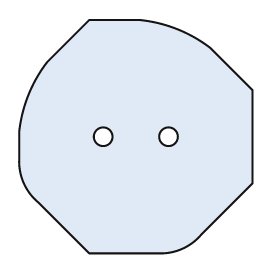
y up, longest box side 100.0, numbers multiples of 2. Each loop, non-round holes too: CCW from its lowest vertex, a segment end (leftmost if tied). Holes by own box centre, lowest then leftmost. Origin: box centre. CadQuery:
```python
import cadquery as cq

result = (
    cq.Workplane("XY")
    .moveTo(-20.0, -50.0)
    .lineTo(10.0, -50.0)
    .threePointArc((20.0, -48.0), (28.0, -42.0))
    .lineTo(50.0, -20.0)
    .lineTo(50.0, 20.0)
    .lineTo(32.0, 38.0)
    .threePointArc((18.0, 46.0), (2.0, 50.0))
    .lineTo(-20.0, 50.0)
    .lineTo(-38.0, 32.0)
    .threePointArc((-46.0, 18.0), (-50.0, 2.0))
    .lineTo(-50.0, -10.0)
    .threePointArc((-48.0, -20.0), (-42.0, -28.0))
    .close()
    .moveTo(-14.0, 0.0)
    .circle(4.0)
    .moveTo(14.0, 0.0)
    .circle(4.0)
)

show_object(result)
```